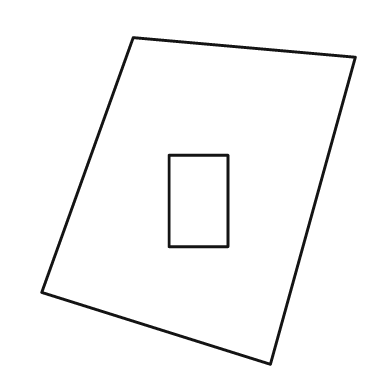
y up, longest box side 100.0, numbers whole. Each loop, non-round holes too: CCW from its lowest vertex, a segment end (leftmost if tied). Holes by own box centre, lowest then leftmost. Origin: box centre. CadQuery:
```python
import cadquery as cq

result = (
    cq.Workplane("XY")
    .moveTo(22.0, -50.0)
    .lineTo(48.0, 44.0)
    .lineTo(-20.0, 50.0)
    .lineTo(-48.0, -28.0)
    .close()
    .moveTo(-9.0, -14.0)
    .lineTo(9.0, -14.0)
    .lineTo(9.0, 14.0)
    .lineTo(-9.0, 14.0)
    .close()
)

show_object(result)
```